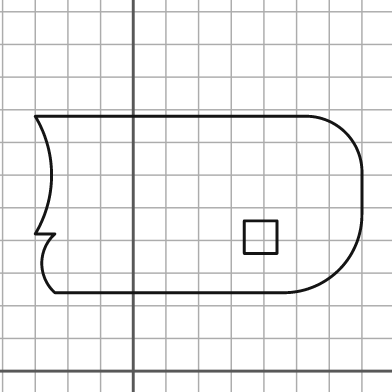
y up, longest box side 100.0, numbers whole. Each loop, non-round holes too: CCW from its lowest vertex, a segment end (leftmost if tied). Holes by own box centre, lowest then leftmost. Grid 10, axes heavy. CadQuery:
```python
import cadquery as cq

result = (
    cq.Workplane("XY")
    .moveTo(-24.0, 24.0)
    .lineTo(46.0, 24.0)
    .threePointArc((63.0, 31.0), (70.0, 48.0))
    .lineTo(70.0, 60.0)
    .threePointArc((65.0, 73.0), (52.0, 78.0))
    .lineTo(-30.0, 78.0)
    .threePointArc((-25.0, 60.0), (-30.0, 42.0))
    .lineTo(-24.0, 42.0)
    .threePointArc((-28.0, 33.0), (-24.0, 24.0))
    .close()
    .moveTo(34.0, 36.0)
    .lineTo(44.0, 36.0)
    .lineTo(44.0, 46.0)
    .lineTo(34.0, 46.0)
    .close()
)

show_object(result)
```